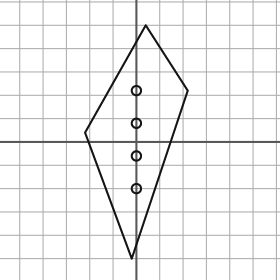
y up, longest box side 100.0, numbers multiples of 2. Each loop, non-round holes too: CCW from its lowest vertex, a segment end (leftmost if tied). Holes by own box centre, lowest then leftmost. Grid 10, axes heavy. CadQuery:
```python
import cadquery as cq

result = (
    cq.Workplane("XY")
    .moveTo(-2.0, -50.0)
    .lineTo(22.0, 22.0)
    .lineTo(4.0, 50.0)
    .lineTo(-22.0, 4.0)
    .close()
    .moveTo(0.0, -20.0)
    .circle(2.0)
    .moveTo(0.0, -6.0)
    .circle(2.0)
    .moveTo(0.0, 8.0)
    .circle(2.0)
    .moveTo(0.0, 22.0)
    .circle(2.0)
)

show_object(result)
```